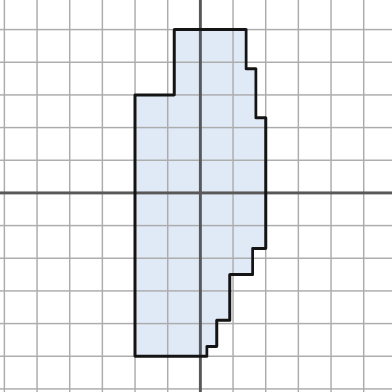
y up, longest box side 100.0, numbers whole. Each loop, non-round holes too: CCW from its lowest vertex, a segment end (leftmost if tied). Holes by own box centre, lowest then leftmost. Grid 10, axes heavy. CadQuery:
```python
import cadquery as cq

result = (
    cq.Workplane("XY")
    .moveTo(-20.0, -50.0)
    .lineTo(2.0, -50.0)
    .lineTo(2.0, -47.0)
    .lineTo(5.0, -47.0)
    .lineTo(5.0, -39.0)
    .lineTo(9.0, -39.0)
    .lineTo(9.0, -25.0)
    .lineTo(16.0, -25.0)
    .lineTo(16.0, -17.0)
    .lineTo(20.0, -17.0)
    .lineTo(20.0, 23.0)
    .lineTo(17.0, 23.0)
    .lineTo(17.0, 38.0)
    .lineTo(14.0, 38.0)
    .lineTo(14.0, 50.0)
    .lineTo(-8.0, 50.0)
    .lineTo(-8.0, 30.0)
    .lineTo(-20.0, 30.0)
    .close()
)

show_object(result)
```